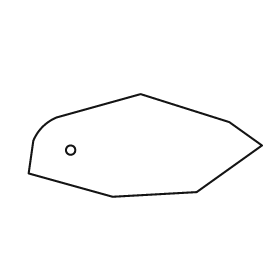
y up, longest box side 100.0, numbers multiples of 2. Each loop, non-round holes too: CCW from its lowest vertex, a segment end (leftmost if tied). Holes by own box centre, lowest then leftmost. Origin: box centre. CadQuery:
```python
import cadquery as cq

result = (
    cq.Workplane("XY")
    .moveTo(-14.0, -22.0)
    .lineTo(22.0, -20.0)
    .lineTo(50.0, 0.0)
    .lineTo(36.0, 10.0)
    .lineTo(-2.0, 22.0)
    .lineTo(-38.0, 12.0)
    .threePointArc((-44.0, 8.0), (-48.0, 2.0))
    .lineTo(-50.0, -12.0)
    .close()
    .moveTo(-32.0, -2.0)
    .circle(2.0)
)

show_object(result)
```